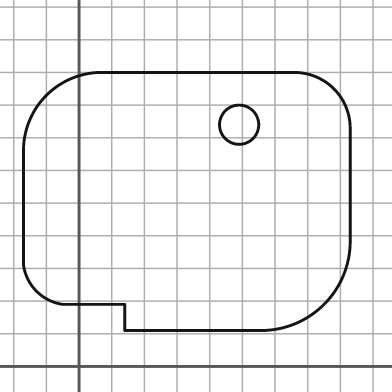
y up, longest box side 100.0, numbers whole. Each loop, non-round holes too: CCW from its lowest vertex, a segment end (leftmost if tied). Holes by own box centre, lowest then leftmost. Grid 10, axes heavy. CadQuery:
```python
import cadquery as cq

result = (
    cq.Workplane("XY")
    .moveTo(14.0, 11.0)
    .lineTo(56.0, 11.0)
    .threePointArc((75.0, 19.0), (83.0, 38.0))
    .lineTo(83.0, 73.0)
    .threePointArc((78.0, 85.0), (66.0, 90.0))
    .lineTo(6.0, 90.0)
    .threePointArc((-10.0, 83.0), (-17.0, 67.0))
    .lineTo(-17.0, 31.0)
    .threePointArc((-13.0, 23.0), (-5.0, 19.0))
    .lineTo(14.0, 19.0)
    .close()
    .moveTo(49.0, 74.0)
    .circle(6.0)
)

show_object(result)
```